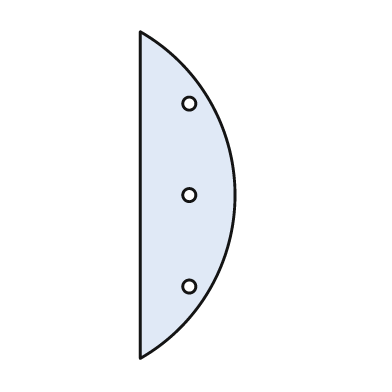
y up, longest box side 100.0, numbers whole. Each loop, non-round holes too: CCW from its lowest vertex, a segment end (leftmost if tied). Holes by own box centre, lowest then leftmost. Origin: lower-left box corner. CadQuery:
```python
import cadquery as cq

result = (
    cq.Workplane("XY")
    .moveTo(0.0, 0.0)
    .threePointArc((29.0, 50.0), (0.0, 100.0))
    .close()
    .moveTo(15.0, 22.0)
    .circle(2.0)
    .moveTo(15.0, 50.0)
    .circle(2.0)
    .moveTo(15.0, 78.0)
    .circle(2.0)
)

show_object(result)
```